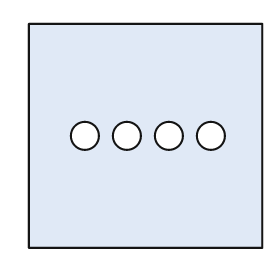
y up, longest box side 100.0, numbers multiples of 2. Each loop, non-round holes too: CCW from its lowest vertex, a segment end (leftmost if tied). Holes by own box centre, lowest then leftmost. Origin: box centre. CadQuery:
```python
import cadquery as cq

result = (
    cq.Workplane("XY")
    .moveTo(-50.0, -48.0)
    .lineTo(50.0, -48.0)
    .lineTo(50.0, 48.0)
    .lineTo(-50.0, 48.0)
    .close()
    .moveTo(-26.0, 0.0)
    .circle(6.0)
    .moveTo(-8.0, 0.0)
    .circle(6.0)
    .moveTo(10.0, 0.0)
    .circle(6.0)
    .moveTo(28.0, 0.0)
    .circle(6.0)
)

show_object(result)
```